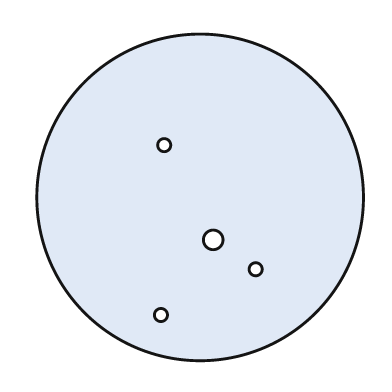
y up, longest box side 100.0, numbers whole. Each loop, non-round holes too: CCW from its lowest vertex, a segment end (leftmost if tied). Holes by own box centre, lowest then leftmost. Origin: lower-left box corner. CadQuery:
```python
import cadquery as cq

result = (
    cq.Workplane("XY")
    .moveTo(50.0, 50.0)
    .circle(50.0)
    .moveTo(38.0, 14.0)
    .circle(2.0)
    .moveTo(67.0, 28.0)
    .circle(2.0)
    .moveTo(54.0, 37.0)
    .circle(3.0)
    .moveTo(39.0, 66.0)
    .circle(2.0)
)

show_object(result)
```